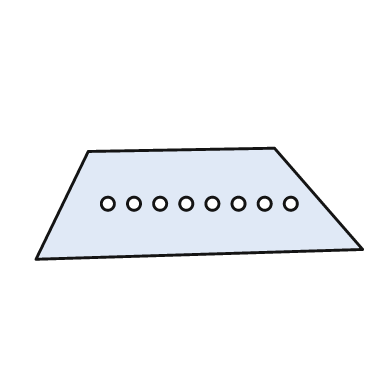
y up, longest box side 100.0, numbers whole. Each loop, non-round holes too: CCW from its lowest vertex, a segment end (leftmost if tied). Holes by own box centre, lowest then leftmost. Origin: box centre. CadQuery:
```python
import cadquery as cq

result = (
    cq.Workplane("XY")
    .moveTo(-50.0, -17.0)
    .lineTo(50.0, -14.0)
    .lineTo(23.0, 17.0)
    .lineTo(-34.0, 16.0)
    .close()
    .moveTo(-28.0, 0.0)
    .circle(2.0)
    .moveTo(-20.0, 0.0)
    .circle(2.0)
    .moveTo(-12.0, 0.0)
    .circle(2.0)
    .moveTo(-4.0, 0.0)
    .circle(2.0)
    .moveTo(4.0, 0.0)
    .circle(2.0)
    .moveTo(12.0, 0.0)
    .circle(2.0)
    .moveTo(20.0, 0.0)
    .circle(2.0)
    .moveTo(28.0, 0.0)
    .circle(2.0)
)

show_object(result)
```